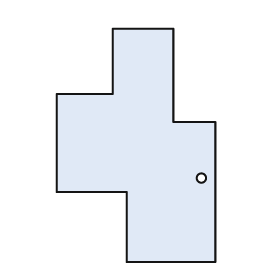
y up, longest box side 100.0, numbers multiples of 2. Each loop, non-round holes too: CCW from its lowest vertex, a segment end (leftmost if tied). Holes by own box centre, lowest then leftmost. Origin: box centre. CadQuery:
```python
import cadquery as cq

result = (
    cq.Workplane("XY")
    .moveTo(-4.0, -50.0)
    .lineTo(34.0, -50.0)
    .lineTo(34.0, 10.0)
    .lineTo(16.0, 10.0)
    .lineTo(16.0, 50.0)
    .lineTo(-10.0, 50.0)
    .lineTo(-10.0, 22.0)
    .lineTo(-34.0, 22.0)
    .lineTo(-34.0, -20.0)
    .lineTo(-4.0, -20.0)
    .close()
    .moveTo(28.0, -14.0)
    .circle(2.0)
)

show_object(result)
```